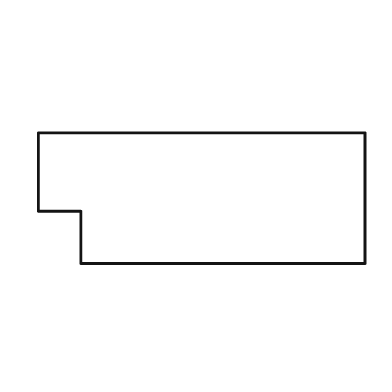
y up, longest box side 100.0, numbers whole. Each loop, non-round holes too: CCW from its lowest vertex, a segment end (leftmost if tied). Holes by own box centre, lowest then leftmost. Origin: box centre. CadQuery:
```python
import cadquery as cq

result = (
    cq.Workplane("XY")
    .moveTo(-37.0, -20.0)
    .lineTo(50.0, -20.0)
    .lineTo(50.0, 20.0)
    .lineTo(-50.0, 20.0)
    .lineTo(-50.0, -4.0)
    .lineTo(-37.0, -4.0)
    .close()
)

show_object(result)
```